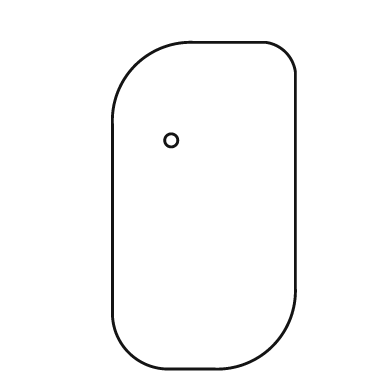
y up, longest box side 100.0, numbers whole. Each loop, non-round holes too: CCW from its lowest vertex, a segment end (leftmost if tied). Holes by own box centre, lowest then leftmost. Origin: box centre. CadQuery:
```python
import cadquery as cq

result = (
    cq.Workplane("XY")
    .moveTo(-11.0, -50.0)
    .lineTo(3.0, -50.0)
    .threePointArc((21.0, -43.0), (28.0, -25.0))
    .lineTo(28.0, 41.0)
    .threePointArc((25.0, 47.0), (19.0, 50.0))
    .lineTo(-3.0, 50.0)
    .threePointArc((-21.0, 43.0), (-28.0, 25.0))
    .lineTo(-28.0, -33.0)
    .threePointArc((-23.0, -45.0), (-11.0, -50.0))
    .close()
    .moveTo(-10.0, 20.0)
    .circle(2.0)
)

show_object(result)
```